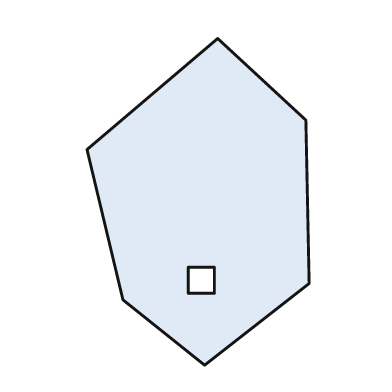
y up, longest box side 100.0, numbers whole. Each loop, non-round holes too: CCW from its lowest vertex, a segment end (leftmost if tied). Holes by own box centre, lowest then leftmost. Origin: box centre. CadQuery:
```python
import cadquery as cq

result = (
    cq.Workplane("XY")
    .moveTo(2.0, -50.0)
    .lineTo(34.0, -25.0)
    .lineTo(33.0, 25.0)
    .lineTo(6.0, 50.0)
    .lineTo(-34.0, 16.0)
    .lineTo(-23.0, -30.0)
    .close()
    .moveTo(-3.0, -28.0)
    .lineTo(5.0, -28.0)
    .lineTo(5.0, -20.0)
    .lineTo(-3.0, -20.0)
    .close()
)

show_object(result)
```